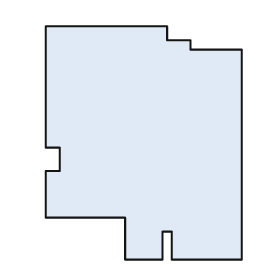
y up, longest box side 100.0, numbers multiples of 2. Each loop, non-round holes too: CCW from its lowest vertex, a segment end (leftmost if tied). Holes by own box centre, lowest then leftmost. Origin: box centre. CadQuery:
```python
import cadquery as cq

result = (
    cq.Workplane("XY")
    .moveTo(-8.0, -50.0)
    .lineTo(8.0, -50.0)
    .lineTo(8.0, -38.0)
    .lineTo(12.0, -38.0)
    .lineTo(12.0, -50.0)
    .lineTo(42.0, -50.0)
    .lineTo(42.0, 40.0)
    .lineTo(20.0, 40.0)
    .lineTo(20.0, 44.0)
    .lineTo(10.0, 44.0)
    .lineTo(10.0, 50.0)
    .lineTo(-42.0, 50.0)
    .lineTo(-42.0, -2.0)
    .lineTo(-36.0, -2.0)
    .lineTo(-36.0, -12.0)
    .lineTo(-42.0, -12.0)
    .lineTo(-42.0, -32.0)
    .lineTo(-8.0, -32.0)
    .close()
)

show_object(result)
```